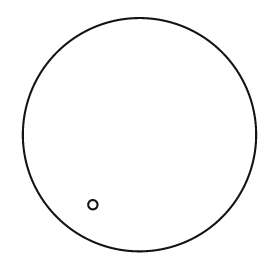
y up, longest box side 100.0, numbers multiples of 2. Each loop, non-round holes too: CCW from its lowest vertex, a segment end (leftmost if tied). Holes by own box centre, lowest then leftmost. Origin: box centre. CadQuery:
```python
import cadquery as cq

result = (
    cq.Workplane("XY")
    .moveTo(0.0, 0.0)
    .circle(50.0)
    .moveTo(-20.0, -30.0)
    .circle(2.0)
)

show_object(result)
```